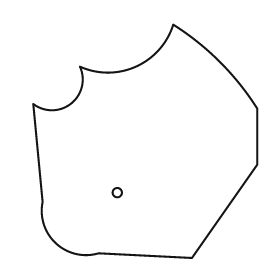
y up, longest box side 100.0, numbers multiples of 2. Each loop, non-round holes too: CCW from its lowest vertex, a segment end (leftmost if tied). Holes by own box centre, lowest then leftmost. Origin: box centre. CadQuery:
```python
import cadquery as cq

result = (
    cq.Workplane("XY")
    .moveTo(20.0, -50.0)
    .lineTo(48.0, -10.0)
    .lineTo(48.0, 14.0)
    .threePointArc((32.0, 34.0), (12.0, 50.0))
    .threePointArc((-4.0, 32.0), (-28.0, 32.0))
    .threePointArc((-32.0, 16.0), (-48.0, 16.0))
    .lineTo(-44.0, -26.0)
    .threePointArc((-38.0, -44.0), (-20.0, -48.0))
    .close()
    .moveTo(-12.0, -22.0)
    .circle(2.0)
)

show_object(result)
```